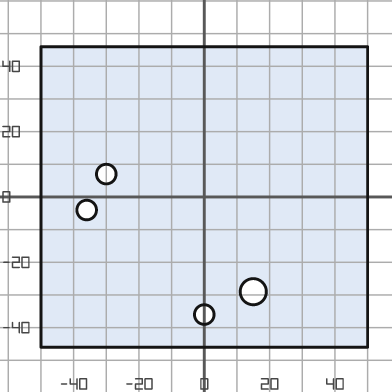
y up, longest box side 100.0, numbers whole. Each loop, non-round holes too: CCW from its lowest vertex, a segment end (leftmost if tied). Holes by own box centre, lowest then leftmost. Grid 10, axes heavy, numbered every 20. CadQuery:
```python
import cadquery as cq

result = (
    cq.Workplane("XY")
    .moveTo(-50.0, -46.0)
    .lineTo(50.0, -46.0)
    .lineTo(50.0, 46.0)
    .lineTo(-50.0, 46.0)
    .close()
    .moveTo(0.0, -36.0)
    .circle(3.0)
    .moveTo(15.0, -29.0)
    .circle(4.0)
    .moveTo(-36.0, -4.0)
    .circle(3.0)
    .moveTo(-30.0, 7.0)
    .circle(3.0)
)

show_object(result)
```